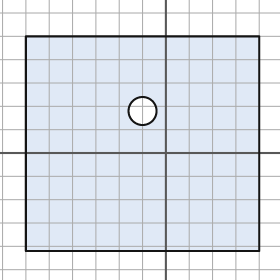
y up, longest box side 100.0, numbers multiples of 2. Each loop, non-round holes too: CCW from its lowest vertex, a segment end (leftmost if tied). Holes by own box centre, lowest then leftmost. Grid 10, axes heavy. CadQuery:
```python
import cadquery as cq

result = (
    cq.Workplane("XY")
    .moveTo(-60.0, -42.0)
    .lineTo(40.0, -42.0)
    .lineTo(40.0, 50.0)
    .lineTo(-60.0, 50.0)
    .close()
    .moveTo(-10.0, 18.0)
    .circle(6.0)
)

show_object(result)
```